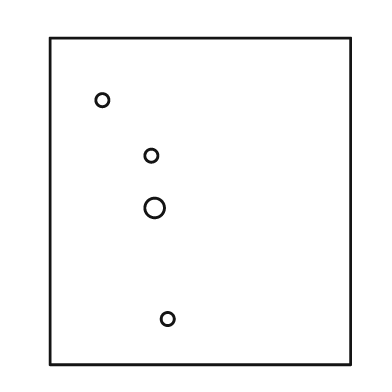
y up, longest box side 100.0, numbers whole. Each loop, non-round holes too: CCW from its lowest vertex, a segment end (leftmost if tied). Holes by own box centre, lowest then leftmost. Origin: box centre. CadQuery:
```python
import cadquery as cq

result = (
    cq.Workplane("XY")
    .moveTo(-46.0, -50.0)
    .lineTo(46.0, -50.0)
    .lineTo(46.0, 50.0)
    .lineTo(-46.0, 50.0)
    .close()
    .moveTo(-10.0, -36.0)
    .circle(2.0)
    .moveTo(-14.0, -2.0)
    .circle(3.0)
    .moveTo(-15.0, 14.0)
    .circle(2.0)
    .moveTo(-30.0, 31.0)
    .circle(2.0)
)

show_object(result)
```